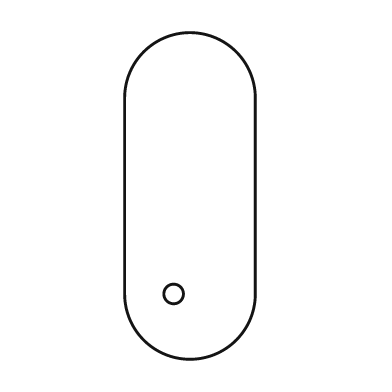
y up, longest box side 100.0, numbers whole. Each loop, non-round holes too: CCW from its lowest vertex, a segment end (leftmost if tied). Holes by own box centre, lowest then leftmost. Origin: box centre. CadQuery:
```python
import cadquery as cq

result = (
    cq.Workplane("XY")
    .moveTo(-20.0, -30.0)
    .threePointArc((0.0, -50.0), (20.0, -30.0))
    .lineTo(20.0, 30.0)
    .threePointArc((0.0, 50.0), (-20.0, 30.0))
    .close()
    .moveTo(-5.0, -30.0)
    .circle(3.0)
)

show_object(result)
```